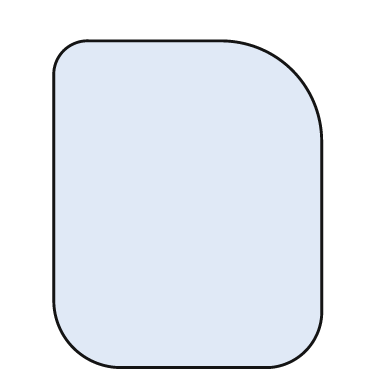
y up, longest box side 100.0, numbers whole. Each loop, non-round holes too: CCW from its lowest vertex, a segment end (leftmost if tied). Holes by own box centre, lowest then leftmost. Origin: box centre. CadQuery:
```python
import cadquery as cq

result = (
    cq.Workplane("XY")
    .moveTo(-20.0, -50.0)
    .lineTo(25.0, -50.0)
    .threePointArc((36.0, -45.0), (41.0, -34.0))
    .lineTo(41.0, 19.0)
    .threePointArc((32.0, 41.0), (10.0, 50.0))
    .lineTo(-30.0, 50.0)
    .threePointArc((-38.0, 47.0), (-41.0, 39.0))
    .lineTo(-41.0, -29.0)
    .threePointArc((-35.0, -44.0), (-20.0, -50.0))
    .close()
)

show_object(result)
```